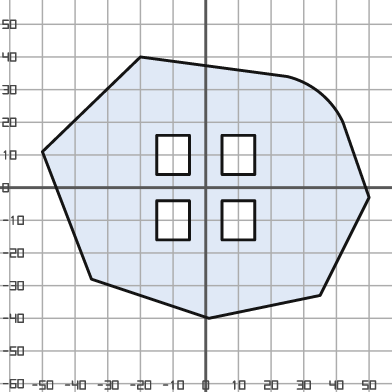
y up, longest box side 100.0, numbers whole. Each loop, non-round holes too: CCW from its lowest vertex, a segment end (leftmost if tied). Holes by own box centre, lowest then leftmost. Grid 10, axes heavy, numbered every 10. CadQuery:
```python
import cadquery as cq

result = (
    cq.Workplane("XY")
    .moveTo(1.0, -40.0)
    .lineTo(35.0, -33.0)
    .lineTo(50.0, -3.0)
    .lineTo(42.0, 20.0)
    .threePointArc((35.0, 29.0), (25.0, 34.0))
    .lineTo(-20.0, 40.0)
    .lineTo(-50.0, 11.0)
    .lineTo(-35.0, -28.0)
    .close()
    .moveTo(-15.0, -16.0)
    .lineTo(-5.0, -16.0)
    .lineTo(-5.0, -4.0)
    .lineTo(-15.0, -4.0)
    .close()
    .moveTo(5.0, -16.0)
    .lineTo(15.0, -16.0)
    .lineTo(15.0, -4.0)
    .lineTo(5.0, -4.0)
    .close()
    .moveTo(-15.0, 4.0)
    .lineTo(-5.0, 4.0)
    .lineTo(-5.0, 16.0)
    .lineTo(-15.0, 16.0)
    .close()
    .moveTo(5.0, 4.0)
    .lineTo(15.0, 4.0)
    .lineTo(15.0, 16.0)
    .lineTo(5.0, 16.0)
    .close()
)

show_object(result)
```